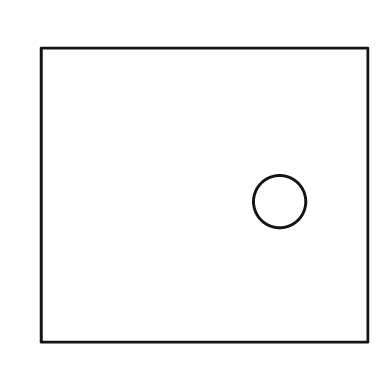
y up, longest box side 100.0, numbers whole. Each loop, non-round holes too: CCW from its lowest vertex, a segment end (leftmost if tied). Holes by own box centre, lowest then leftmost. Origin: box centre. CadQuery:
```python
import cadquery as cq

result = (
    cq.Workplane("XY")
    .moveTo(-50.0, -45.0)
    .lineTo(50.0, -45.0)
    .lineTo(50.0, 45.0)
    .lineTo(-50.0, 45.0)
    .close()
    .moveTo(23.0, -2.0)
    .circle(8.0)
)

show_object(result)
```